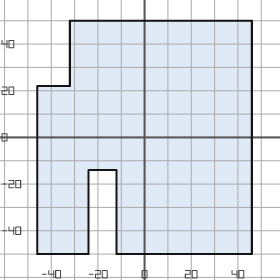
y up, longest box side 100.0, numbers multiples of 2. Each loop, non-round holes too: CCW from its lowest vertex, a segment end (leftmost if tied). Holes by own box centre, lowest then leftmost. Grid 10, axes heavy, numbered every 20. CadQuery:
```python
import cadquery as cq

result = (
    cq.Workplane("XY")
    .moveTo(-46.0, -50.0)
    .lineTo(-24.0, -50.0)
    .lineTo(-24.0, -14.0)
    .lineTo(-12.0, -14.0)
    .lineTo(-12.0, -50.0)
    .lineTo(46.0, -50.0)
    .lineTo(46.0, 50.0)
    .lineTo(-32.0, 50.0)
    .lineTo(-32.0, 22.0)
    .lineTo(-46.0, 22.0)
    .close()
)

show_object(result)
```